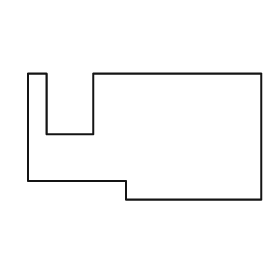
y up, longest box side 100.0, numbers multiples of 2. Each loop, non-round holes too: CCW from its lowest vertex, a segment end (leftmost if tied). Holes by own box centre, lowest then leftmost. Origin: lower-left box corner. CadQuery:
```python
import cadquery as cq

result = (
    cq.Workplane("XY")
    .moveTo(42.0, 0.0)
    .lineTo(100.0, 0.0)
    .lineTo(100.0, 54.0)
    .lineTo(28.0, 54.0)
    .lineTo(28.0, 28.0)
    .lineTo(8.0, 28.0)
    .lineTo(8.0, 54.0)
    .lineTo(0.0, 54.0)
    .lineTo(0.0, 8.0)
    .lineTo(42.0, 8.0)
    .close()
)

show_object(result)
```